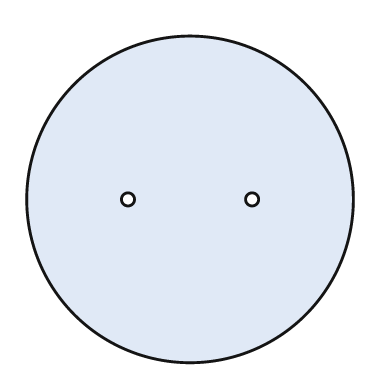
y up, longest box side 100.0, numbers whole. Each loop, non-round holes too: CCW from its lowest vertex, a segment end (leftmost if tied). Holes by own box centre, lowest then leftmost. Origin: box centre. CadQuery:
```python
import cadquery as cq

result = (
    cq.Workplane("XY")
    .moveTo(0.0, 0.0)
    .circle(50.0)
    .moveTo(-19.0, 0.0)
    .circle(2.0)
    .moveTo(19.0, 0.0)
    .circle(2.0)
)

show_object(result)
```